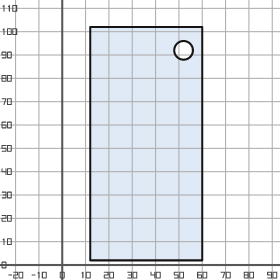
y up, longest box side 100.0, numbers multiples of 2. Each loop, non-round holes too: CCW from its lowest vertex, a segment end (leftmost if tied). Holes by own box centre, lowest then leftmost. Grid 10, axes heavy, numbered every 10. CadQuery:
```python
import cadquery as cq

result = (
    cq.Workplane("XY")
    .moveTo(12.0, 2.0)
    .lineTo(60.0, 2.0)
    .lineTo(60.0, 102.0)
    .lineTo(12.0, 102.0)
    .close()
    .moveTo(52.0, 92.0)
    .circle(4.0)
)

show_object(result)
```